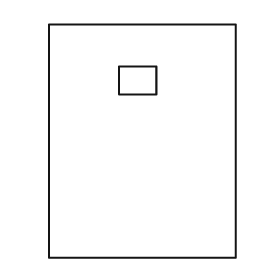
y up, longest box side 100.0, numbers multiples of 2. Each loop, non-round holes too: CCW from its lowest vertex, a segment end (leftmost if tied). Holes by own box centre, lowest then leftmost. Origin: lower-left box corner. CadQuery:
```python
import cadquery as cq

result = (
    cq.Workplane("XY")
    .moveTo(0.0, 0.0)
    .lineTo(80.0, 0.0)
    .lineTo(80.0, 100.0)
    .lineTo(0.0, 100.0)
    .close()
    .moveTo(30.0, 70.0)
    .lineTo(46.0, 70.0)
    .lineTo(46.0, 82.0)
    .lineTo(30.0, 82.0)
    .close()
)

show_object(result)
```